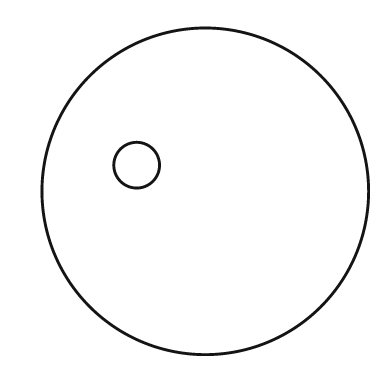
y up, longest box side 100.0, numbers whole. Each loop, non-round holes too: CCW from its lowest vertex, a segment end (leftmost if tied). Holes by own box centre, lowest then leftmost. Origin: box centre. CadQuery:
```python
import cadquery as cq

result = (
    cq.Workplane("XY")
    .moveTo(0.0, 0.0)
    .circle(50.0)
    .moveTo(-21.0, 8.0)
    .circle(7.0)
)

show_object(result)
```